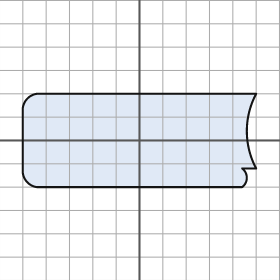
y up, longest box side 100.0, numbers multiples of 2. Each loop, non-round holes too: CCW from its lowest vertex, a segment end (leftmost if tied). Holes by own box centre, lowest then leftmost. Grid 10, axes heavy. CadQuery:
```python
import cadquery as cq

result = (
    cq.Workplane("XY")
    .moveTo(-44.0, -20.0)
    .lineTo(44.0, -20.0)
    .threePointArc((46.0, -16.0), (44.0, -12.0))
    .lineTo(50.0, -12.0)
    .threePointArc((46.0, 4.0), (50.0, 20.0))
    .lineTo(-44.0, 20.0)
    .threePointArc((-48.0, 18.0), (-50.0, 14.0))
    .lineTo(-50.0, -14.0)
    .threePointArc((-48.0, -18.0), (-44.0, -20.0))
    .close()
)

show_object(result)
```